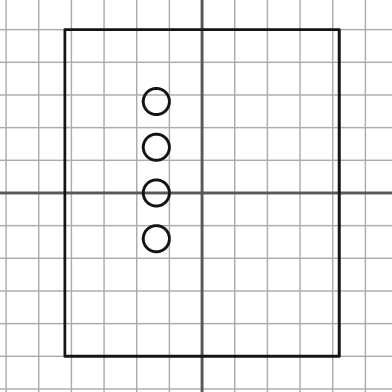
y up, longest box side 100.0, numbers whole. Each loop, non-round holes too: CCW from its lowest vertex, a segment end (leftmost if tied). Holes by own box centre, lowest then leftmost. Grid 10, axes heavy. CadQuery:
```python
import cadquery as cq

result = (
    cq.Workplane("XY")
    .moveTo(-42.0, -50.0)
    .lineTo(42.0, -50.0)
    .lineTo(42.0, 50.0)
    .lineTo(-42.0, 50.0)
    .close()
    .moveTo(-14.0, -14.0)
    .circle(4.0)
    .moveTo(-14.0, 0.0)
    .circle(4.0)
    .moveTo(-14.0, 14.0)
    .circle(4.0)
    .moveTo(-14.0, 28.0)
    .circle(4.0)
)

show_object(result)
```